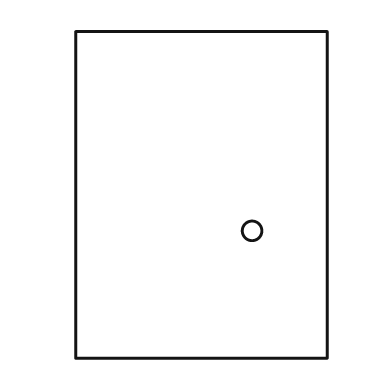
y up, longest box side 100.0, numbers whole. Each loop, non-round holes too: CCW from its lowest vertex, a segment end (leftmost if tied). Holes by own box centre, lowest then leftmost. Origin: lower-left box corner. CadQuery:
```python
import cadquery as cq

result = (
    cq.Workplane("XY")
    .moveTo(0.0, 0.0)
    .lineTo(77.0, 0.0)
    .lineTo(77.0, 100.0)
    .lineTo(0.0, 100.0)
    .close()
    .moveTo(54.0, 39.0)
    .circle(3.0)
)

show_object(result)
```